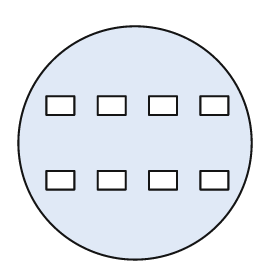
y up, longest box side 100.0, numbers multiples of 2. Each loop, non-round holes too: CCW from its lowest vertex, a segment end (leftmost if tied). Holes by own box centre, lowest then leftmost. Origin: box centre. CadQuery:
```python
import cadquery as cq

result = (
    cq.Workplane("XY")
    .moveTo(0.0, 0.0)
    .circle(50.0)
    .moveTo(-38.0, -20.0)
    .lineTo(-26.0, -20.0)
    .lineTo(-26.0, -12.0)
    .lineTo(-38.0, -12.0)
    .close()
    .moveTo(-16.0, -20.0)
    .lineTo(-4.0, -20.0)
    .lineTo(-4.0, -12.0)
    .lineTo(-16.0, -12.0)
    .close()
    .moveTo(6.0, -20.0)
    .lineTo(18.0, -20.0)
    .lineTo(18.0, -12.0)
    .lineTo(6.0, -12.0)
    .close()
    .moveTo(28.0, -20.0)
    .lineTo(40.0, -20.0)
    .lineTo(40.0, -12.0)
    .lineTo(28.0, -12.0)
    .close()
    .moveTo(-38.0, 12.0)
    .lineTo(-26.0, 12.0)
    .lineTo(-26.0, 20.0)
    .lineTo(-38.0, 20.0)
    .close()
    .moveTo(-16.0, 12.0)
    .lineTo(-4.0, 12.0)
    .lineTo(-4.0, 20.0)
    .lineTo(-16.0, 20.0)
    .close()
    .moveTo(6.0, 12.0)
    .lineTo(18.0, 12.0)
    .lineTo(18.0, 20.0)
    .lineTo(6.0, 20.0)
    .close()
    .moveTo(28.0, 12.0)
    .lineTo(40.0, 12.0)
    .lineTo(40.0, 20.0)
    .lineTo(28.0, 20.0)
    .close()
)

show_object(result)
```